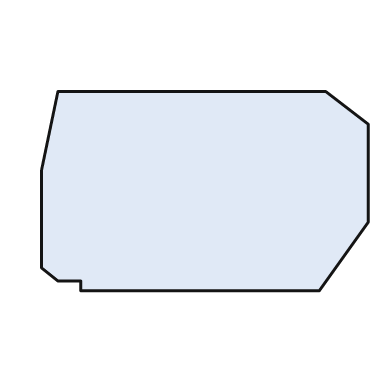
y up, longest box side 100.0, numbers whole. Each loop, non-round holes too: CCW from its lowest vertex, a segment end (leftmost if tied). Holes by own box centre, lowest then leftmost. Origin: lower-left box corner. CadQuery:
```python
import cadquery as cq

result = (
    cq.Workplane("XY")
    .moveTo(12.0, 0.0)
    .lineTo(85.0, 0.0)
    .lineTo(100.0, 21.0)
    .lineTo(100.0, 51.0)
    .lineTo(87.0, 61.0)
    .lineTo(5.0, 61.0)
    .lineTo(0.0, 37.0)
    .lineTo(0.0, 7.0)
    .lineTo(5.0, 3.0)
    .lineTo(12.0, 3.0)
    .close()
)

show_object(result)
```